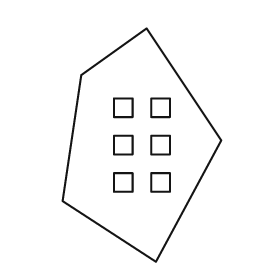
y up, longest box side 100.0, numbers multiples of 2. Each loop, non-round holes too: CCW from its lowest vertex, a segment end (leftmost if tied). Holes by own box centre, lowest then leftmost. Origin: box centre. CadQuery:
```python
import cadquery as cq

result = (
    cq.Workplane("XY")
    .moveTo(6.0, -50.0)
    .lineTo(34.0, 2.0)
    .lineTo(2.0, 50.0)
    .lineTo(-26.0, 30.0)
    .lineTo(-34.0, -24.0)
    .close()
    .moveTo(-12.0, -20.0)
    .lineTo(-4.0, -20.0)
    .lineTo(-4.0, -12.0)
    .lineTo(-12.0, -12.0)
    .close()
    .moveTo(4.0, -20.0)
    .lineTo(12.0, -20.0)
    .lineTo(12.0, -12.0)
    .lineTo(4.0, -12.0)
    .close()
    .moveTo(-12.0, -4.0)
    .lineTo(-4.0, -4.0)
    .lineTo(-4.0, 4.0)
    .lineTo(-12.0, 4.0)
    .close()
    .moveTo(4.0, -4.0)
    .lineTo(12.0, -4.0)
    .lineTo(12.0, 4.0)
    .lineTo(4.0, 4.0)
    .close()
    .moveTo(-12.0, 12.0)
    .lineTo(-4.0, 12.0)
    .lineTo(-4.0, 20.0)
    .lineTo(-12.0, 20.0)
    .close()
    .moveTo(4.0, 12.0)
    .lineTo(12.0, 12.0)
    .lineTo(12.0, 20.0)
    .lineTo(4.0, 20.0)
    .close()
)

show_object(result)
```